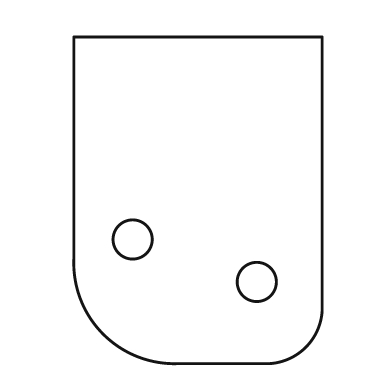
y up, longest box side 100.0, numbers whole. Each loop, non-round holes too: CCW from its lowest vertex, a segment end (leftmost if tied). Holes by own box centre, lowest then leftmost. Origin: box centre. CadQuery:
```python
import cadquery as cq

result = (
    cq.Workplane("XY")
    .moveTo(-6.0, -50.0)
    .lineTo(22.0, -50.0)
    .threePointArc((33.0, -45.0), (38.0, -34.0))
    .lineTo(38.0, 50.0)
    .lineTo(-38.0, 50.0)
    .lineTo(-38.0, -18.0)
    .threePointArc((-29.0, -41.0), (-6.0, -50.0))
    .close()
    .moveTo(18.0, -25.0)
    .circle(6.0)
    .moveTo(-20.0, -12.0)
    .circle(6.0)
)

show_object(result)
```